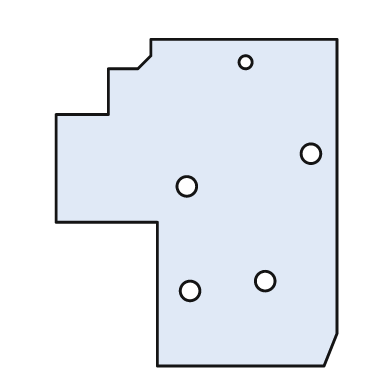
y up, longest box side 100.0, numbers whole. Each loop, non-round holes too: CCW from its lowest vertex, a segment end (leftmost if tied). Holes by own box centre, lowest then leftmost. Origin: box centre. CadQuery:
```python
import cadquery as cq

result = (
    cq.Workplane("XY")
    .moveTo(-12.0, -50.0)
    .lineTo(39.0, -50.0)
    .lineTo(43.0, -40.0)
    .lineTo(43.0, 50.0)
    .lineTo(-14.0, 50.0)
    .lineTo(-14.0, 45.0)
    .lineTo(-18.0, 41.0)
    .lineTo(-27.0, 41.0)
    .lineTo(-27.0, 27.0)
    .lineTo(-43.0, 27.0)
    .lineTo(-43.0, -6.0)
    .lineTo(-12.0, -6.0)
    .close()
    .moveTo(-2.0, -27.0)
    .circle(3.0)
    .moveTo(21.0, -24.0)
    .circle(3.0)
    .moveTo(-3.0, 5.0)
    .circle(3.0)
    .moveTo(35.0, 15.0)
    .circle(3.0)
    .moveTo(15.0, 43.0)
    .circle(2.0)
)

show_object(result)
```